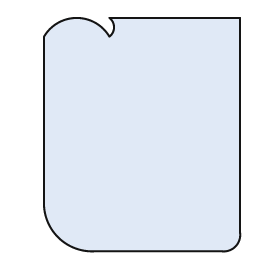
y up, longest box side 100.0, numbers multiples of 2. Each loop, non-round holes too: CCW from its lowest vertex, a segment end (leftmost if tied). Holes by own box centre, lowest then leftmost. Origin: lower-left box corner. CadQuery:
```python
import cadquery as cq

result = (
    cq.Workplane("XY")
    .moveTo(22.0, 0.0)
    .lineTo(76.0, 0.0)
    .threePointArc((82.0, 2.0), (84.0, 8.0))
    .lineTo(84.0, 100.0)
    .lineTo(28.0, 100.0)
    .threePointArc((30.0, 96.0), (28.0, 92.0))
    .threePointArc((14.0, 100.0), (0.0, 92.0))
    .lineTo(0.0, 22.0)
    .threePointArc((6.0, 6.0), (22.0, 0.0))
    .close()
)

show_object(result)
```